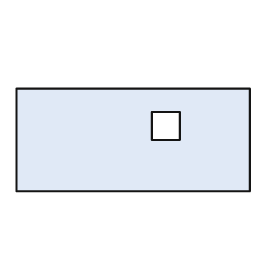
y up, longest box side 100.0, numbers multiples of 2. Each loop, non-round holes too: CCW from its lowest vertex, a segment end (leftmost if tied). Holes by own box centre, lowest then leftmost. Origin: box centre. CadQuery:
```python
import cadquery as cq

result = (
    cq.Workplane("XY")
    .moveTo(-50.0, -22.0)
    .lineTo(50.0, -22.0)
    .lineTo(50.0, 22.0)
    .lineTo(-50.0, 22.0)
    .close()
    .moveTo(8.0, 0.0)
    .lineTo(20.0, 0.0)
    .lineTo(20.0, 12.0)
    .lineTo(8.0, 12.0)
    .close()
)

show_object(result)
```